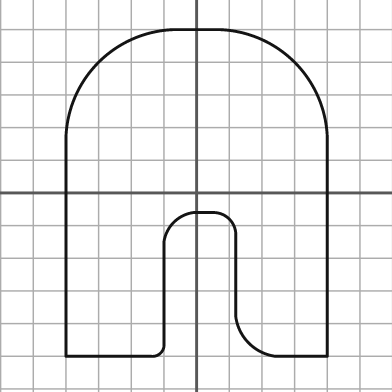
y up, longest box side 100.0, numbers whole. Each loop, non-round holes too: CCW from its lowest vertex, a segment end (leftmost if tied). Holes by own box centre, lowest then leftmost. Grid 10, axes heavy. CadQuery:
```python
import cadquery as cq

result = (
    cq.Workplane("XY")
    .moveTo(-40.0, -50.0)
    .lineTo(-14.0, -50.0)
    .threePointArc((-11.0, -49.0), (-10.0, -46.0))
    .lineTo(-10.0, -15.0)
    .threePointArc((-7.0, -9.0), (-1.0, -6.0))
    .lineTo(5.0, -6.0)
    .threePointArc((10.0, -8.0), (12.0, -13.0))
    .lineTo(12.0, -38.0)
    .threePointArc((16.0, -46.0), (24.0, -50.0))
    .lineTo(40.0, -50.0)
    .lineTo(40.0, 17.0)
    .threePointArc((30.0, 40.0), (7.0, 50.0))
    .lineTo(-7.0, 50.0)
    .threePointArc((-30.0, 40.0), (-40.0, 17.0))
    .close()
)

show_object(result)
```